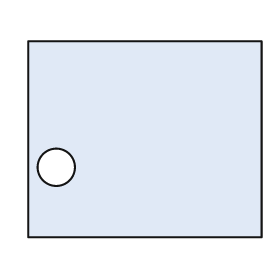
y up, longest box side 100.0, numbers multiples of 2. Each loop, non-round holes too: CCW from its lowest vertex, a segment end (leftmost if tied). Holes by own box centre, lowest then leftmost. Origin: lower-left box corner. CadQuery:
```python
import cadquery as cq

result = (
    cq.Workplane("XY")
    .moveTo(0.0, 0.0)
    .lineTo(100.0, 0.0)
    .lineTo(100.0, 84.0)
    .lineTo(0.0, 84.0)
    .close()
    .moveTo(12.0, 30.0)
    .circle(8.0)
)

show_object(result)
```